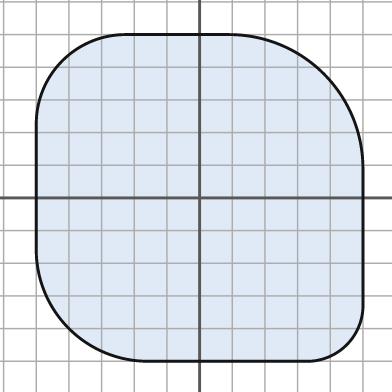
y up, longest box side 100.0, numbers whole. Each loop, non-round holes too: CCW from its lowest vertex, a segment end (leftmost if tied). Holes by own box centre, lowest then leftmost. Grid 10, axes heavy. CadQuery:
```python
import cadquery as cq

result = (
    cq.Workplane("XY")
    .moveTo(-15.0, -50.0)
    .lineTo(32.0, -50.0)
    .threePointArc((45.0, -45.0), (50.0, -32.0))
    .lineTo(50.0, 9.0)
    .threePointArc((38.0, 38.0), (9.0, 50.0))
    .lineTo(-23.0, 50.0)
    .threePointArc((-42.0, 42.0), (-50.0, 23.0))
    .lineTo(-50.0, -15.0)
    .threePointArc((-40.0, -40.0), (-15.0, -50.0))
    .close()
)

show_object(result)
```